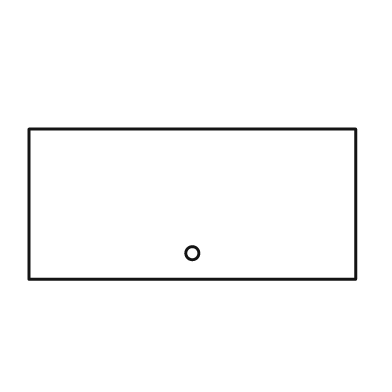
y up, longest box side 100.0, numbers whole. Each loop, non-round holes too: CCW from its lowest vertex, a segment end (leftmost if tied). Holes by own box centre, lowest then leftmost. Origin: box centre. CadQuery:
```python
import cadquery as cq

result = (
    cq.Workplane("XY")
    .moveTo(-50.0, -23.0)
    .lineTo(50.0, -23.0)
    .lineTo(50.0, 23.0)
    .lineTo(-50.0, 23.0)
    .close()
    .moveTo(0.0, -15.0)
    .circle(2.0)
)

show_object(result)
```